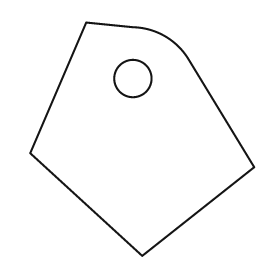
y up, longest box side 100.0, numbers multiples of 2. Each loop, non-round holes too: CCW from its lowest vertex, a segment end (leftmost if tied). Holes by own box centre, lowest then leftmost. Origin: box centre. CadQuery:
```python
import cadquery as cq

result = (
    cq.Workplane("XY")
    .moveTo(0.0, -50.0)
    .lineTo(48.0, -12.0)
    .lineTo(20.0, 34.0)
    .threePointArc((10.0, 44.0), (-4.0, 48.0))
    .lineTo(-24.0, 50.0)
    .lineTo(-48.0, -6.0)
    .close()
    .moveTo(-4.0, 26.0)
    .circle(8.0)
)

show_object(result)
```